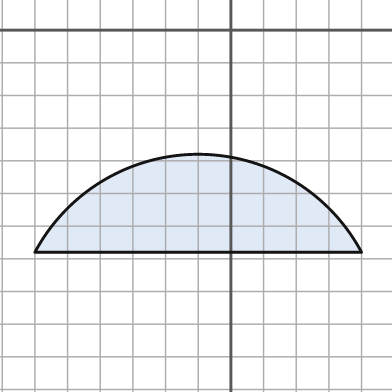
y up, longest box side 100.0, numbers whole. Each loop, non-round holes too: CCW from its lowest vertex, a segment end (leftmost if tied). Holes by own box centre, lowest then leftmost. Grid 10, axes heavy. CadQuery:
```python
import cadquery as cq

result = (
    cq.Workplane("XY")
    .moveTo(-60.0, -68.0)
    .lineTo(40.0, -68.0)
    .threePointArc((-10.0, -38.0), (-60.0, -68.0))
    .close()
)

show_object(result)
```